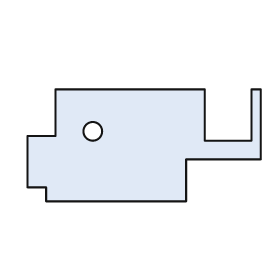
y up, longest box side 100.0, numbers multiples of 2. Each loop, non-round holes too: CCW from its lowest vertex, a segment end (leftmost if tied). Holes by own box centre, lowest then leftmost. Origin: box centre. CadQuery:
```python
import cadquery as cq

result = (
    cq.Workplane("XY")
    .moveTo(-42.0, -24.0)
    .lineTo(18.0, -24.0)
    .lineTo(18.0, -6.0)
    .lineTo(50.0, -6.0)
    .lineTo(50.0, 24.0)
    .lineTo(46.0, 24.0)
    .lineTo(46.0, 2.0)
    .lineTo(26.0, 2.0)
    .lineTo(26.0, 24.0)
    .lineTo(-38.0, 24.0)
    .lineTo(-38.0, 4.0)
    .lineTo(-50.0, 4.0)
    .lineTo(-50.0, -18.0)
    .lineTo(-42.0, -18.0)
    .close()
    .moveTo(-22.0, 6.0)
    .circle(4.0)
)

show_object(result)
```